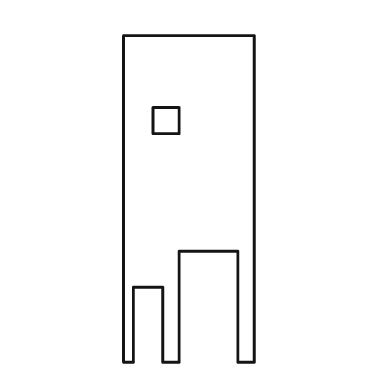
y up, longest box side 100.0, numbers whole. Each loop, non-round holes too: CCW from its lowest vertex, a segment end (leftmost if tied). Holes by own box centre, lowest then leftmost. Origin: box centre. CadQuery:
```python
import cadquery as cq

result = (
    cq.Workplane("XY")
    .moveTo(-20.0, -50.0)
    .lineTo(-17.0, -50.0)
    .lineTo(-17.0, -27.0)
    .lineTo(-8.0, -27.0)
    .lineTo(-8.0, -50.0)
    .lineTo(-3.0, -50.0)
    .lineTo(-3.0, -16.0)
    .lineTo(15.0, -16.0)
    .lineTo(15.0, -50.0)
    .lineTo(20.0, -50.0)
    .lineTo(20.0, 50.0)
    .lineTo(-20.0, 50.0)
    .close()
    .moveTo(-11.0, 20.0)
    .lineTo(-3.0, 20.0)
    .lineTo(-3.0, 28.0)
    .lineTo(-11.0, 28.0)
    .close()
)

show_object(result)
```